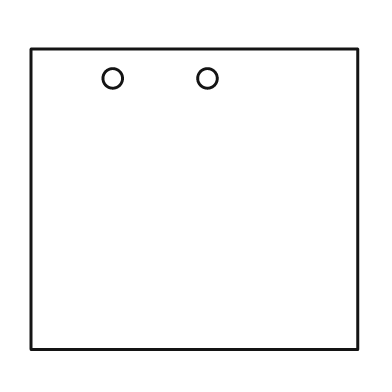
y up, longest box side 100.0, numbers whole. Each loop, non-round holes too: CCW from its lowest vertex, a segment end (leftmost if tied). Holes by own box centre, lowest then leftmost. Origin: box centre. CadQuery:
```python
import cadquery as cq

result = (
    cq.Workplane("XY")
    .moveTo(-50.0, -46.0)
    .lineTo(50.0, -46.0)
    .lineTo(50.0, 46.0)
    .lineTo(-50.0, 46.0)
    .close()
    .moveTo(-25.0, 37.0)
    .circle(3.0)
    .moveTo(4.0, 37.0)
    .circle(3.0)
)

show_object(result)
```